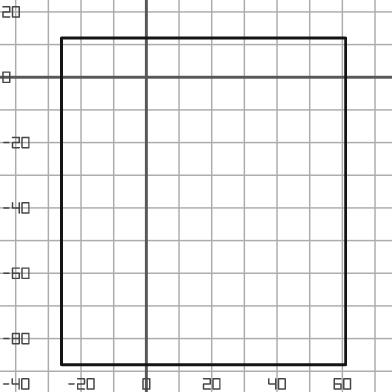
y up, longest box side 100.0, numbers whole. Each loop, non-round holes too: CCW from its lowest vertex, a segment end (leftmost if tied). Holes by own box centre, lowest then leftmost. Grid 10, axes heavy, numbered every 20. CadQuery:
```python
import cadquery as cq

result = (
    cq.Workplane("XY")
    .moveTo(-26.0, -88.0)
    .lineTo(61.0, -88.0)
    .lineTo(61.0, 12.0)
    .lineTo(-26.0, 12.0)
    .close()
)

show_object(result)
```